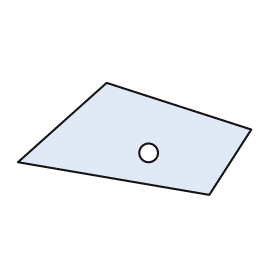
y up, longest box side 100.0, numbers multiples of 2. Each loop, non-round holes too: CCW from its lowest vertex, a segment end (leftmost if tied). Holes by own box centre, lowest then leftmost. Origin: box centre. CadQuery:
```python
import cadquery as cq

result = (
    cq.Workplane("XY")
    .moveTo(32.0, -24.0)
    .lineTo(50.0, 4.0)
    .lineTo(-12.0, 24.0)
    .lineTo(-50.0, -10.0)
    .close()
    .moveTo(6.0, -6.0)
    .circle(4.0)
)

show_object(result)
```